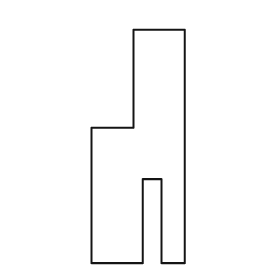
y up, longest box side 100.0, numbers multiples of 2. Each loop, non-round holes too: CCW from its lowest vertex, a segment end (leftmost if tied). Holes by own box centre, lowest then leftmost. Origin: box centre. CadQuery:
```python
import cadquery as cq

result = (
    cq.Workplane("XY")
    .moveTo(-20.0, -50.0)
    .lineTo(2.0, -50.0)
    .lineTo(2.0, -14.0)
    .lineTo(10.0, -14.0)
    .lineTo(10.0, -50.0)
    .lineTo(20.0, -50.0)
    .lineTo(20.0, 50.0)
    .lineTo(-2.0, 50.0)
    .lineTo(-2.0, 8.0)
    .lineTo(-20.0, 8.0)
    .close()
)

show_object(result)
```